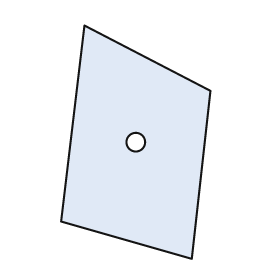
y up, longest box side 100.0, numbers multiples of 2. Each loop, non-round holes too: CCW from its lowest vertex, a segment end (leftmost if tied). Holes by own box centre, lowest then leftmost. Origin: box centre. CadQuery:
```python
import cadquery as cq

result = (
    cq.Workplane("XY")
    .moveTo(24.0, -50.0)
    .lineTo(32.0, 22.0)
    .lineTo(-22.0, 50.0)
    .lineTo(-32.0, -34.0)
    .close()
    .moveTo(0.0, 0.0)
    .circle(4.0)
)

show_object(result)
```